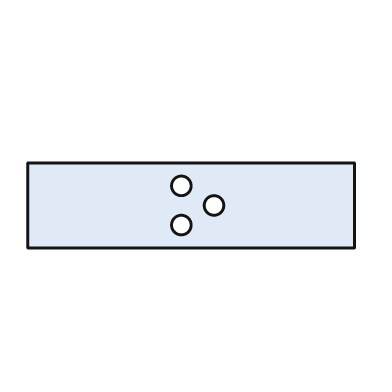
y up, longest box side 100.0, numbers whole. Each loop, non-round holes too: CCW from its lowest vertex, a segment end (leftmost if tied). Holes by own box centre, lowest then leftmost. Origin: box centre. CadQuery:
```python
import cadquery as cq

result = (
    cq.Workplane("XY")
    .moveTo(-50.0, -13.0)
    .lineTo(50.0, -13.0)
    .lineTo(50.0, 13.0)
    .lineTo(-50.0, 13.0)
    .close()
    .moveTo(-3.0, -6.0)
    .circle(3.0)
    .moveTo(7.0, 0.0)
    .circle(3.0)
    .moveTo(-3.0, 6.0)
    .circle(3.0)
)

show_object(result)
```